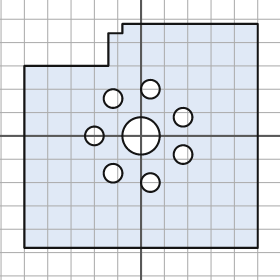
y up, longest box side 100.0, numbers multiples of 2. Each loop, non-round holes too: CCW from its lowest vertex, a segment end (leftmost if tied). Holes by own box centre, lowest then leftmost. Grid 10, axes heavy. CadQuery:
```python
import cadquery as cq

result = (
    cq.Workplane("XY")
    .moveTo(-50.0, -48.0)
    .lineTo(50.0, -48.0)
    .lineTo(50.0, 48.0)
    .lineTo(-8.0, 48.0)
    .lineTo(-8.0, 44.0)
    .lineTo(-14.0, 44.0)
    .lineTo(-14.0, 30.0)
    .lineTo(-50.0, 30.0)
    .close()
    .moveTo(4.0, -20.0)
    .circle(4.0)
    .moveTo(-12.0, -16.0)
    .circle(4.0)
    .moveTo(18.0, -8.0)
    .circle(4.0)
    .moveTo(-20.0, 0.0)
    .circle(4.0)
    .moveTo(0.0, 0.0)
    .circle(8.0)
    .moveTo(18.0, 8.0)
    .circle(4.0)
    .moveTo(-12.0, 16.0)
    .circle(4.0)
    .moveTo(4.0, 20.0)
    .circle(4.0)
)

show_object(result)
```